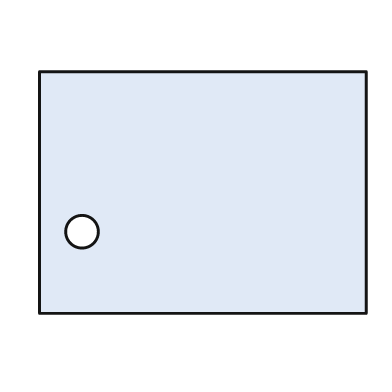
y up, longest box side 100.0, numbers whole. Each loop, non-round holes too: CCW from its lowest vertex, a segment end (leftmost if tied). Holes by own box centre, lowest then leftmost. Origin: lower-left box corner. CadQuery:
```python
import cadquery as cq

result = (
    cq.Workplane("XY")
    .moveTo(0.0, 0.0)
    .lineTo(100.0, 0.0)
    .lineTo(100.0, 74.0)
    .lineTo(0.0, 74.0)
    .close()
    .moveTo(13.0, 25.0)
    .circle(5.0)
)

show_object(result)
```